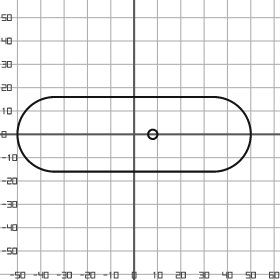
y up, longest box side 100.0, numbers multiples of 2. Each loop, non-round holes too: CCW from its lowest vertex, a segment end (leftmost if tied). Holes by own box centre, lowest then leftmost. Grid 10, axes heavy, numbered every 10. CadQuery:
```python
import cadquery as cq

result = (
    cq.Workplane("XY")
    .moveTo(-34.0, -16.0)
    .lineTo(34.0, -16.0)
    .threePointArc((50.0, 0.0), (34.0, 16.0))
    .lineTo(-34.0, 16.0)
    .threePointArc((-50.0, 0.0), (-34.0, -16.0))
    .close()
    .moveTo(8.0, 0.0)
    .circle(2.0)
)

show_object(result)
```